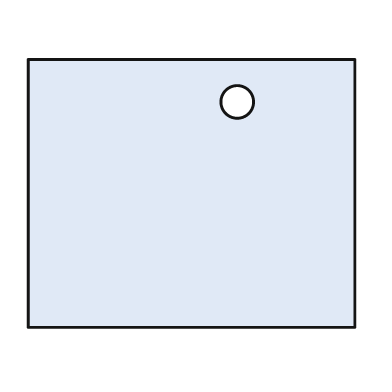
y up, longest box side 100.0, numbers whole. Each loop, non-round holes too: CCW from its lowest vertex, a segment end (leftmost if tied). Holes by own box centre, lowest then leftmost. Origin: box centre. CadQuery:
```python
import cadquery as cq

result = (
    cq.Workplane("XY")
    .moveTo(-50.0, -41.0)
    .lineTo(50.0, -41.0)
    .lineTo(50.0, 41.0)
    .lineTo(-50.0, 41.0)
    .close()
    .moveTo(14.0, 28.0)
    .circle(5.0)
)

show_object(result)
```